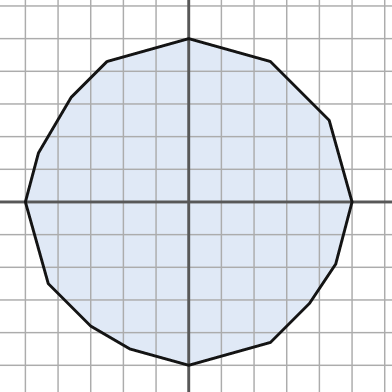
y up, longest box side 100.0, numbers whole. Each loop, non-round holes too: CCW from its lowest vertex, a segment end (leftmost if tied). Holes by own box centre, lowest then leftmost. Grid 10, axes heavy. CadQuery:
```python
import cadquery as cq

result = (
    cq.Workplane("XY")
    .moveTo(0.0, -50.0)
    .lineTo(25.0, -43.0)
    .lineTo(37.0, -31.0)
    .lineTo(45.0, -19.0)
    .lineTo(50.0, 0.0)
    .lineTo(43.0, 25.0)
    .lineTo(25.0, 43.0)
    .lineTo(0.0, 50.0)
    .lineTo(-25.0, 43.0)
    .lineTo(-36.0, 32.0)
    .lineTo(-46.0, 15.0)
    .lineTo(-50.0, 0.0)
    .lineTo(-43.0, -25.0)
    .lineTo(-30.0, -38.0)
    .lineTo(-18.0, -45.0)
    .close()
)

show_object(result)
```